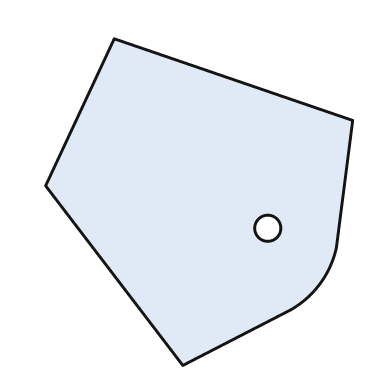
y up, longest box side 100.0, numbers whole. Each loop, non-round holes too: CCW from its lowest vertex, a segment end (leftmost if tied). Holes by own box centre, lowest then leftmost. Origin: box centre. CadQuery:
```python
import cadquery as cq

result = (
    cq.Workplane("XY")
    .moveTo(-5.0, -50.0)
    .lineTo(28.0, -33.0)
    .threePointArc((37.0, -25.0), (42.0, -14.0))
    .lineTo(47.0, 25.0)
    .lineTo(-26.0, 50.0)
    .lineTo(-47.0, 5.0)
    .close()
    .moveTo(21.0, -8.0)
    .circle(4.0)
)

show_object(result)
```